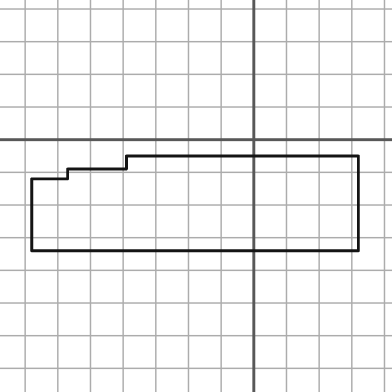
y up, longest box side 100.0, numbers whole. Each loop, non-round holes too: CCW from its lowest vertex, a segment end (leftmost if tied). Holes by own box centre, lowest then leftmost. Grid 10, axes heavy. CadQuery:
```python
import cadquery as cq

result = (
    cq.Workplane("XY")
    .moveTo(-68.0, -34.0)
    .lineTo(32.0, -34.0)
    .lineTo(32.0, -5.0)
    .lineTo(-39.0, -5.0)
    .lineTo(-39.0, -9.0)
    .lineTo(-57.0, -9.0)
    .lineTo(-57.0, -12.0)
    .lineTo(-68.0, -12.0)
    .close()
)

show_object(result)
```